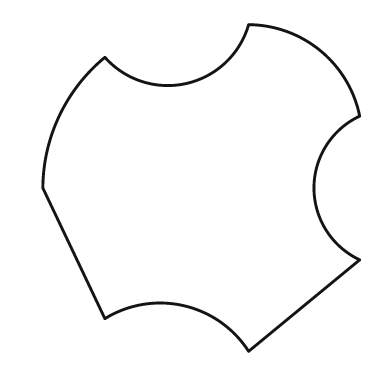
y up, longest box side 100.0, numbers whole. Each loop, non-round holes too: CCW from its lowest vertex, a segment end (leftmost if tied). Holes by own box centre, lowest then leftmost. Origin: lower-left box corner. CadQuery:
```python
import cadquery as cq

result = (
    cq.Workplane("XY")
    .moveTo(63.0, 0.0)
    .lineTo(97.0, 28.0)
    .threePointArc((83.0, 50.0), (97.0, 72.0))
    .threePointArc((85.0, 92.0), (63.0, 100.0))
    .threePointArc((44.0, 82.0), (19.0, 90.0))
    .threePointArc((5.0, 72.0), (0.0, 50.0))
    .lineTo(19.0, 10.0)
    .threePointArc((43.0, 14.0), (63.0, 0.0))
    .close()
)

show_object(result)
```